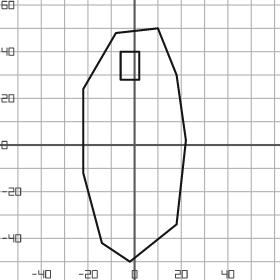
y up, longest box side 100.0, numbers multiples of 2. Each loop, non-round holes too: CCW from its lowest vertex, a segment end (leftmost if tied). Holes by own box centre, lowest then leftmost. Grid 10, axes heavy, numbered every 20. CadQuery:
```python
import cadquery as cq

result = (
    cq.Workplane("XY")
    .moveTo(-2.0, -50.0)
    .lineTo(18.0, -34.0)
    .lineTo(22.0, 2.0)
    .lineTo(18.0, 30.0)
    .lineTo(10.0, 50.0)
    .lineTo(-8.0, 48.0)
    .lineTo(-22.0, 24.0)
    .lineTo(-22.0, -12.0)
    .lineTo(-14.0, -42.0)
    .close()
    .moveTo(-6.0, 28.0)
    .lineTo(2.0, 28.0)
    .lineTo(2.0, 40.0)
    .lineTo(-6.0, 40.0)
    .close()
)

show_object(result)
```